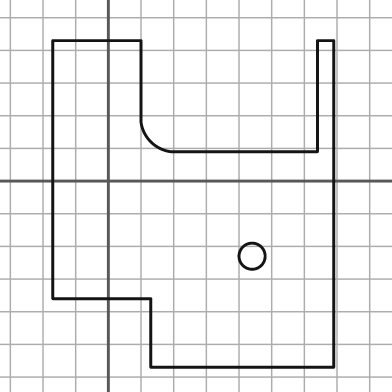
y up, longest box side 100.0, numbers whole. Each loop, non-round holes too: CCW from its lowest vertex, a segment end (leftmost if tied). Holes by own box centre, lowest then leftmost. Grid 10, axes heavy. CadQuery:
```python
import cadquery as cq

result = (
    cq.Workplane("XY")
    .moveTo(13.0, -57.0)
    .lineTo(69.0, -57.0)
    .lineTo(69.0, 43.0)
    .lineTo(64.0, 43.0)
    .lineTo(64.0, 9.0)
    .lineTo(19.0, 9.0)
    .threePointArc((13.0, 12.0), (10.0, 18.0))
    .lineTo(10.0, 43.0)
    .lineTo(-17.0, 43.0)
    .lineTo(-17.0, -36.0)
    .lineTo(13.0, -36.0)
    .close()
    .moveTo(44.0, -23.0)
    .circle(4.0)
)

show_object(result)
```